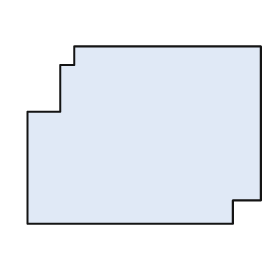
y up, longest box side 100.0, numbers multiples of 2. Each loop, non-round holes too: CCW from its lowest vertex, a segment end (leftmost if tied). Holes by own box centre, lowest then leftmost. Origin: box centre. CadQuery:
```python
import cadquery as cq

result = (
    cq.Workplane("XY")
    .moveTo(-50.0, -38.0)
    .lineTo(38.0, -38.0)
    .lineTo(38.0, -28.0)
    .lineTo(50.0, -28.0)
    .lineTo(50.0, 38.0)
    .lineTo(-30.0, 38.0)
    .lineTo(-30.0, 30.0)
    .lineTo(-36.0, 30.0)
    .lineTo(-36.0, 10.0)
    .lineTo(-50.0, 10.0)
    .close()
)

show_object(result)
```